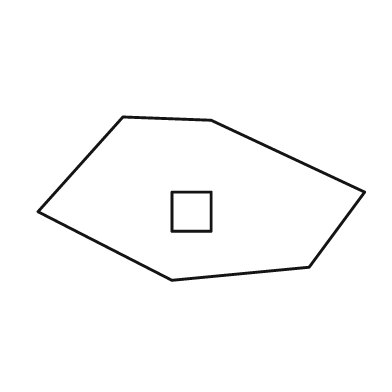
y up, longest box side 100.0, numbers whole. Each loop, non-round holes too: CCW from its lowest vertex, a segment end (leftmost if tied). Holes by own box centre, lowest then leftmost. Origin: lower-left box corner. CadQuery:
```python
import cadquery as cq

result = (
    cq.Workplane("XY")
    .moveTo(41.0, 0.0)
    .lineTo(83.0, 4.0)
    .lineTo(100.0, 27.0)
    .lineTo(53.0, 49.0)
    .lineTo(26.0, 50.0)
    .lineTo(0.0, 21.0)
    .close()
    .moveTo(41.0, 15.0)
    .lineTo(53.0, 15.0)
    .lineTo(53.0, 27.0)
    .lineTo(41.0, 27.0)
    .close()
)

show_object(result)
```